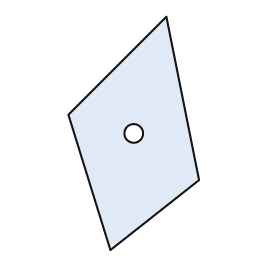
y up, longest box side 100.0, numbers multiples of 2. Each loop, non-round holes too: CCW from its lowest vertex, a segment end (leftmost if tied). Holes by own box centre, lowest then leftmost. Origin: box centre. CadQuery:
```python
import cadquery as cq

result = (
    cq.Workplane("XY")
    .moveTo(-10.0, -50.0)
    .lineTo(28.0, -20.0)
    .lineTo(14.0, 50.0)
    .lineTo(-28.0, 8.0)
    .close()
    .moveTo(0.0, 0.0)
    .circle(4.0)
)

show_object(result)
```